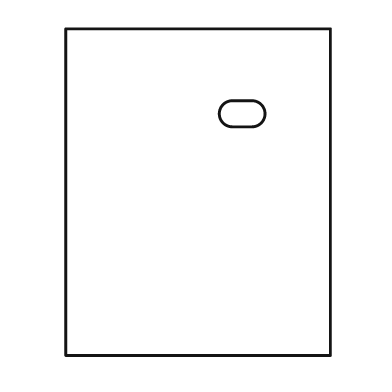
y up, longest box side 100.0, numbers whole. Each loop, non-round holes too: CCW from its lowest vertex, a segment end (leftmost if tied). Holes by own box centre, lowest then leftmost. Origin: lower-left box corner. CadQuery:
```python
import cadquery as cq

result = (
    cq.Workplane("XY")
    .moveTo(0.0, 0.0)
    .lineTo(81.0, 0.0)
    .lineTo(81.0, 100.0)
    .lineTo(0.0, 100.0)
    .close()
    .moveTo(51.0, 70.0)
    .lineTo(57.0, 70.0)
    .threePointArc((61.0, 74.0), (57.0, 78.0))
    .lineTo(51.0, 78.0)
    .threePointArc((47.0, 74.0), (51.0, 70.0))
    .close()
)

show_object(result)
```